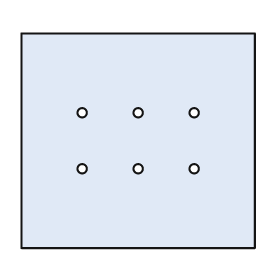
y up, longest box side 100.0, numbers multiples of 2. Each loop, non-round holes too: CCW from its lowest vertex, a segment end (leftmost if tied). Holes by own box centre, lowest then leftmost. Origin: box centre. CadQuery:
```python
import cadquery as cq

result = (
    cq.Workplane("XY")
    .moveTo(-50.0, -46.0)
    .lineTo(50.0, -46.0)
    .lineTo(50.0, 46.0)
    .lineTo(-50.0, 46.0)
    .close()
    .moveTo(-24.0, -12.0)
    .circle(2.0)
    .moveTo(0.0, -12.0)
    .circle(2.0)
    .moveTo(24.0, -12.0)
    .circle(2.0)
    .moveTo(-24.0, 12.0)
    .circle(2.0)
    .moveTo(0.0, 12.0)
    .circle(2.0)
    .moveTo(24.0, 12.0)
    .circle(2.0)
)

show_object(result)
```